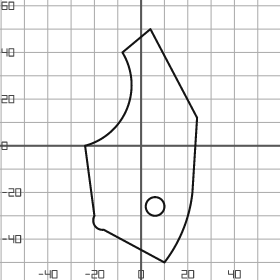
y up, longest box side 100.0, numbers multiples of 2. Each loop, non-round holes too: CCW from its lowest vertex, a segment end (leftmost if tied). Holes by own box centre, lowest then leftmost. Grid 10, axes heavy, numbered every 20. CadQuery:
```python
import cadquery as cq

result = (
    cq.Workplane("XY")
    .moveTo(10.0, -50.0)
    .threePointArc((18.0, -36.0), (22.0, -20.0))
    .lineTo(24.0, 12.0)
    .lineTo(4.0, 50.0)
    .lineTo(-8.0, 40.0)
    .threePointArc((-6.0, 16.0), (-24.0, 0.0))
    .lineTo(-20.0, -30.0)
    .threePointArc((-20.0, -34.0), (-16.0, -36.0))
    .close()
    .moveTo(6.0, -26.0)
    .circle(4.0)
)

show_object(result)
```